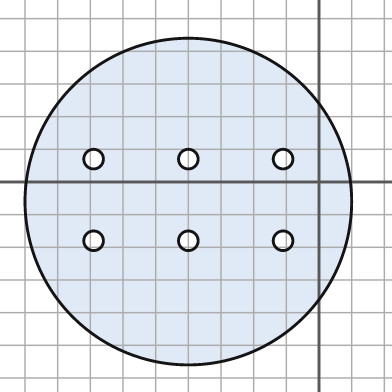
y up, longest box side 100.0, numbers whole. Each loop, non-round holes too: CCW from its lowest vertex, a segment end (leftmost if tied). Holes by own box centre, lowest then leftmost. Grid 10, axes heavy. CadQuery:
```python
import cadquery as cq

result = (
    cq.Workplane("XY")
    .moveTo(-40.0, -6.0)
    .circle(50.0)
    .moveTo(-69.0, -18.0)
    .circle(3.0)
    .moveTo(-40.0, -18.0)
    .circle(3.0)
    .moveTo(-11.0, -18.0)
    .circle(3.0)
    .moveTo(-69.0, 7.0)
    .circle(3.0)
    .moveTo(-40.0, 7.0)
    .circle(3.0)
    .moveTo(-11.0, 7.0)
    .circle(3.0)
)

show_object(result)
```